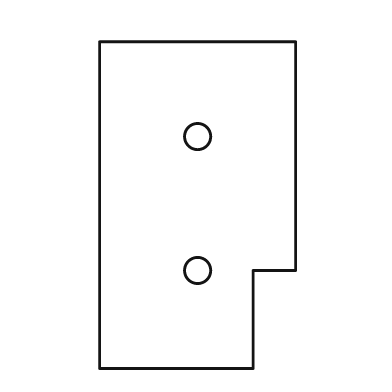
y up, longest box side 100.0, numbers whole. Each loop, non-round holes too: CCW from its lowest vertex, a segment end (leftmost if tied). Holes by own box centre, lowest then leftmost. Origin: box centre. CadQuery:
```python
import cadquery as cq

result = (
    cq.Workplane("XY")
    .moveTo(-30.0, -50.0)
    .lineTo(17.0, -50.0)
    .lineTo(17.0, -20.0)
    .lineTo(30.0, -20.0)
    .lineTo(30.0, 50.0)
    .lineTo(-30.0, 50.0)
    .close()
    .moveTo(0.0, -20.0)
    .circle(4.0)
    .moveTo(0.0, 21.0)
    .circle(4.0)
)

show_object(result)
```